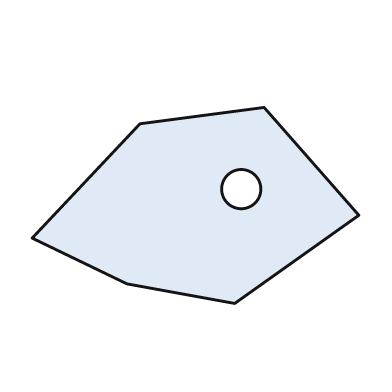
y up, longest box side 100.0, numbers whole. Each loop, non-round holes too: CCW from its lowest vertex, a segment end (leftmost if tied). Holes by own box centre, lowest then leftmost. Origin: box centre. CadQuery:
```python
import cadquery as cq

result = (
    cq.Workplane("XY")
    .moveTo(12.0, -30.0)
    .lineTo(50.0, -3.0)
    .lineTo(21.0, 30.0)
    .lineTo(-17.0, 25.0)
    .lineTo(-50.0, -10.0)
    .lineTo(-21.0, -24.0)
    .close()
    .moveTo(14.0, 5.0)
    .circle(6.0)
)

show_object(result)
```